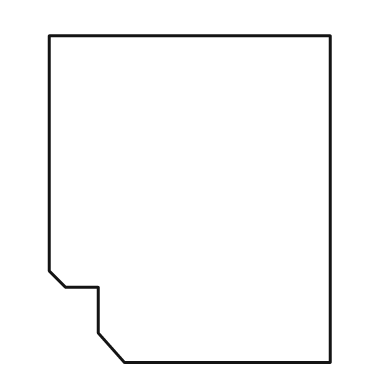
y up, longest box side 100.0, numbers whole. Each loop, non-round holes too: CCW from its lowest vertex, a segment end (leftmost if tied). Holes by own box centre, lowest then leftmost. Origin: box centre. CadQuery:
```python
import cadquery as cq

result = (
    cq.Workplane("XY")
    .moveTo(-20.0, -50.0)
    .lineTo(43.0, -50.0)
    .lineTo(43.0, 50.0)
    .lineTo(-43.0, 50.0)
    .lineTo(-43.0, -22.0)
    .lineTo(-38.0, -27.0)
    .lineTo(-28.0, -27.0)
    .lineTo(-28.0, -41.0)
    .close()
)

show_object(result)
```